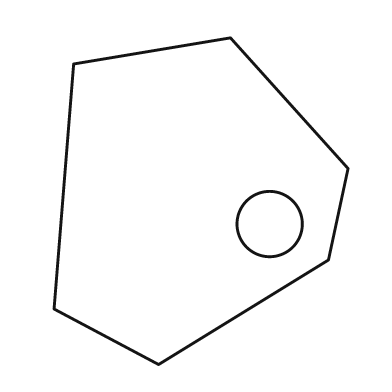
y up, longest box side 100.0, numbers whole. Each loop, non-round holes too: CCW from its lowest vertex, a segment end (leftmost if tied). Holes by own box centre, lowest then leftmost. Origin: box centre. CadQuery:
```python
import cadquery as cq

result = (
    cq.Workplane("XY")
    .moveTo(-13.0, -50.0)
    .lineTo(39.0, -18.0)
    .lineTo(45.0, 10.0)
    .lineTo(9.0, 50.0)
    .lineTo(-39.0, 42.0)
    .lineTo(-45.0, -33.0)
    .close()
    .moveTo(21.0, -7.0)
    .circle(10.0)
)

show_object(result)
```